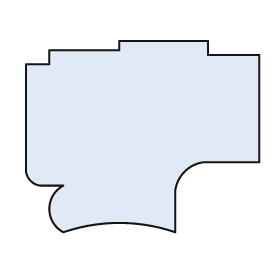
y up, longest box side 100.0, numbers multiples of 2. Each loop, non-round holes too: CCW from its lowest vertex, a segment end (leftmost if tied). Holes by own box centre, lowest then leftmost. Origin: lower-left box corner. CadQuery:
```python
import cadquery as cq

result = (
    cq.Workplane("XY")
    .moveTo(16.0, 0.0)
    .threePointArc((40.0, 4.0), (64.0, 0.0))
    .lineTo(64.0, 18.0)
    .threePointArc((68.0, 26.0), (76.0, 30.0))
    .lineTo(100.0, 30.0)
    .lineTo(100.0, 76.0)
    .lineTo(78.0, 76.0)
    .lineTo(78.0, 82.0)
    .lineTo(40.0, 82.0)
    .lineTo(40.0, 78.0)
    .lineTo(10.0, 78.0)
    .lineTo(10.0, 72.0)
    .lineTo(0.0, 72.0)
    .lineTo(0.0, 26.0)
    .threePointArc((2.0, 22.0), (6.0, 20.0))
    .lineTo(16.0, 20.0)
    .threePointArc((10.0, 10.0), (16.0, 0.0))
    .close()
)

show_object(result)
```